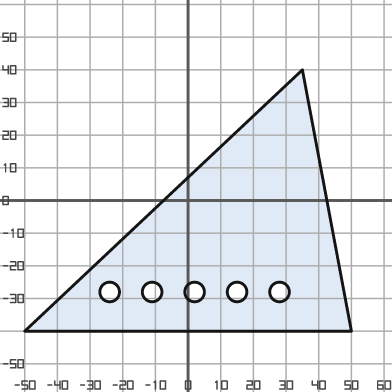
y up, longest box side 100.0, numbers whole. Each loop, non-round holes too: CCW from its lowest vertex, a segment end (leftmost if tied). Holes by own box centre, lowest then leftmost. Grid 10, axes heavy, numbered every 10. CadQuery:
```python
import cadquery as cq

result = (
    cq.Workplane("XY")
    .moveTo(-50.0, -40.0)
    .lineTo(50.0, -40.0)
    .lineTo(35.0, 40.0)
    .close()
    .moveTo(-24.0, -28.0)
    .circle(3.0)
    .moveTo(-11.0, -28.0)
    .circle(3.0)
    .moveTo(2.0, -28.0)
    .circle(3.0)
    .moveTo(15.0, -28.0)
    .circle(3.0)
    .moveTo(28.0, -28.0)
    .circle(3.0)
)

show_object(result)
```